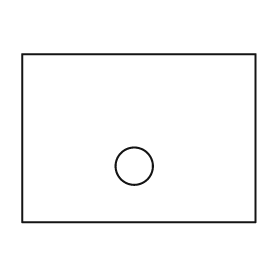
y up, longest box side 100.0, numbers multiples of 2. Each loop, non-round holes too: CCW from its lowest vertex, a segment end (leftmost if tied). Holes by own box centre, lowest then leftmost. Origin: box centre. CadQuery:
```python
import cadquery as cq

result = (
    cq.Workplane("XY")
    .moveTo(-50.0, -36.0)
    .lineTo(50.0, -36.0)
    .lineTo(50.0, 36.0)
    .lineTo(-50.0, 36.0)
    .close()
    .moveTo(-2.0, -12.0)
    .circle(8.0)
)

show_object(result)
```